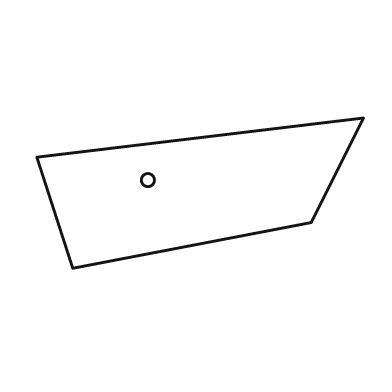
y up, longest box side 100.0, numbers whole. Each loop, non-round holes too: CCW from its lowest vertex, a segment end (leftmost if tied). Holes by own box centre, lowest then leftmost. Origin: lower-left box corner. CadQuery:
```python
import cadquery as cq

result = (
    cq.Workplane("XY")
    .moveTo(11.0, 0.0)
    .lineTo(84.0, 14.0)
    .lineTo(100.0, 46.0)
    .lineTo(0.0, 34.0)
    .close()
    .moveTo(34.0, 27.0)
    .circle(2.0)
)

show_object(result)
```